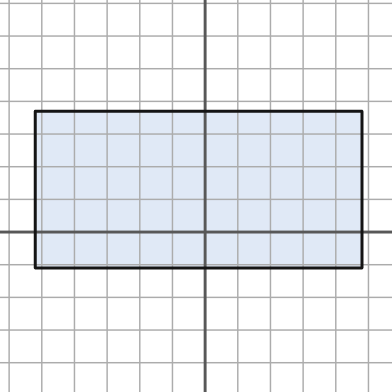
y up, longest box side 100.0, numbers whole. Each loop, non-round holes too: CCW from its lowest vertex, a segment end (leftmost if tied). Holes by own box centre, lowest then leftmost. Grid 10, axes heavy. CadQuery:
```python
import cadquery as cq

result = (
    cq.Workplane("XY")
    .moveTo(-52.0, -11.0)
    .lineTo(48.0, -11.0)
    .lineTo(48.0, 37.0)
    .lineTo(-52.0, 37.0)
    .close()
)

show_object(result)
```